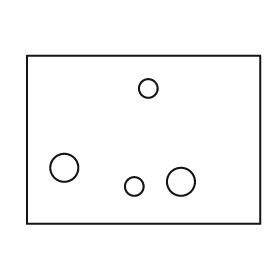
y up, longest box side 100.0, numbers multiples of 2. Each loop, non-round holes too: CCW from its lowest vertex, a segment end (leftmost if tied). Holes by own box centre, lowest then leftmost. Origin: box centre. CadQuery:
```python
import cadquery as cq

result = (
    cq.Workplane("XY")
    .moveTo(-50.0, -36.0)
    .lineTo(50.0, -36.0)
    .lineTo(50.0, 36.0)
    .lineTo(-50.0, 36.0)
    .close()
    .moveTo(-4.0, -20.0)
    .circle(4.0)
    .moveTo(16.0, -18.0)
    .circle(6.0)
    .moveTo(-34.0, -12.0)
    .circle(6.0)
    .moveTo(2.0, 22.0)
    .circle(4.0)
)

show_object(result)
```